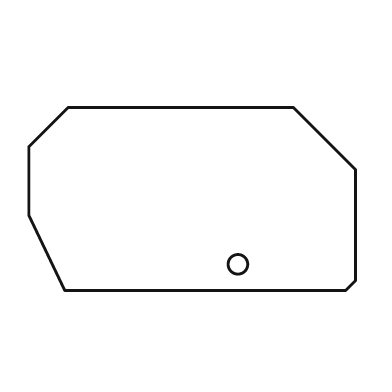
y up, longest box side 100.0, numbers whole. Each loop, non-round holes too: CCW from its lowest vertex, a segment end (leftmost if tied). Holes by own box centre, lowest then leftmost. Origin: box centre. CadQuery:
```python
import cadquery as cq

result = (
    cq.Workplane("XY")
    .moveTo(-39.0, -28.0)
    .lineTo(47.0, -28.0)
    .lineTo(50.0, -25.0)
    .lineTo(50.0, 9.0)
    .lineTo(31.0, 28.0)
    .lineTo(-38.0, 28.0)
    .lineTo(-50.0, 16.0)
    .lineTo(-50.0, -5.0)
    .close()
    .moveTo(14.0, -20.0)
    .circle(3.0)
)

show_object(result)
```